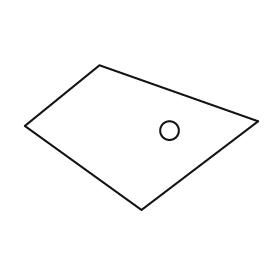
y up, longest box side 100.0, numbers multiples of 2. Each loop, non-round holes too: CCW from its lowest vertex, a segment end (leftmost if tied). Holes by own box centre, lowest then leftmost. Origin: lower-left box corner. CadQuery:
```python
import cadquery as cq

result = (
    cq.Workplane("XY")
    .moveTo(50.0, 0.0)
    .lineTo(100.0, 38.0)
    .lineTo(32.0, 62.0)
    .lineTo(0.0, 36.0)
    .close()
    .moveTo(62.0, 34.0)
    .circle(4.0)
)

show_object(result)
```